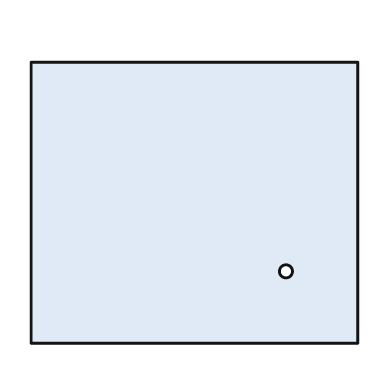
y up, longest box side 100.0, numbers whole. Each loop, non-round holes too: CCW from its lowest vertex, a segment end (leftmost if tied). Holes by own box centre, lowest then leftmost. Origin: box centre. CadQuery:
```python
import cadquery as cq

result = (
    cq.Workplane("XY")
    .moveTo(-50.0, -43.0)
    .lineTo(50.0, -43.0)
    .lineTo(50.0, 43.0)
    .lineTo(-50.0, 43.0)
    .close()
    .moveTo(28.0, -21.0)
    .circle(2.0)
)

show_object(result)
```